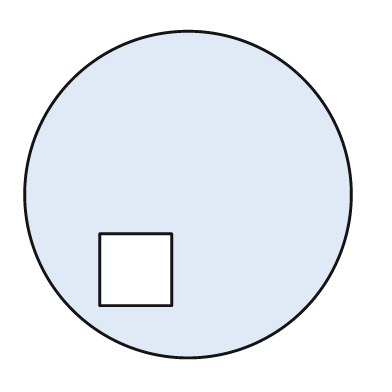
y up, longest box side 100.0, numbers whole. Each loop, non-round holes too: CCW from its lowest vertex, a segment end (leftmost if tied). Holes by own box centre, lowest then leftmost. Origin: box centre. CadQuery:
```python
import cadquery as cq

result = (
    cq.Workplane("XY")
    .moveTo(0.0, 0.0)
    .circle(50.0)
    .moveTo(-27.0, -34.0)
    .lineTo(-5.0, -34.0)
    .lineTo(-5.0, -12.0)
    .lineTo(-27.0, -12.0)
    .close()
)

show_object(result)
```